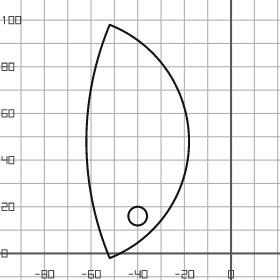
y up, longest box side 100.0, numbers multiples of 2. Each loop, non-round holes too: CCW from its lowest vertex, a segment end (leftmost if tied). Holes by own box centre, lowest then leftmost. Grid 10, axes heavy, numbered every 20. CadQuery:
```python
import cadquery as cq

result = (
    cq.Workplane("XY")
    .moveTo(-52.0, -2.0)
    .threePointArc((-18.0, 48.0), (-52.0, 98.0))
    .threePointArc((-62.0, 48.0), (-52.0, -2.0))
    .close()
    .moveTo(-40.0, 16.0)
    .circle(4.0)
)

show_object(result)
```